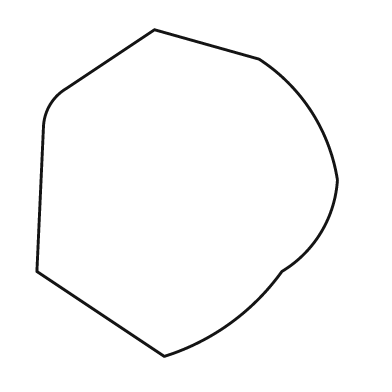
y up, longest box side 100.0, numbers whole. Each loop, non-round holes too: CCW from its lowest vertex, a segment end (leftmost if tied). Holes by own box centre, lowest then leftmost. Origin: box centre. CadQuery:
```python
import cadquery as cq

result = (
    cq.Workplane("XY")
    .moveTo(-7.0, -50.0)
    .threePointArc((13.0, -40.0), (29.0, -24.0))
    .threePointArc((41.0, -12.0), (46.0, 4.0))
    .threePointArc((38.0, 25.0), (22.0, 41.0))
    .lineTo(-10.0, 50.0)
    .lineTo(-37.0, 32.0)
    .threePointArc((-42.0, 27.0), (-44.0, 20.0))
    .lineTo(-46.0, -24.0)
    .close()
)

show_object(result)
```